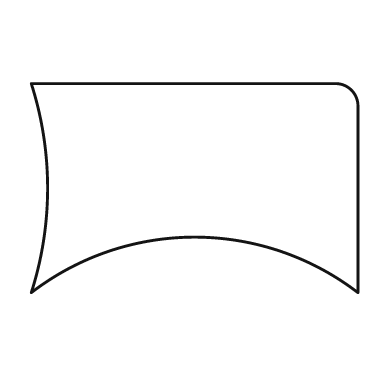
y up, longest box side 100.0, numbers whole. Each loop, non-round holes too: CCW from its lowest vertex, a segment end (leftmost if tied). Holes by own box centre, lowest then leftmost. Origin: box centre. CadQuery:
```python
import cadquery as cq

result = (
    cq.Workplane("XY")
    .moveTo(-50.0, -32.0)
    .threePointArc((0.0, -15.0), (50.0, -32.0))
    .lineTo(50.0, 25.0)
    .threePointArc((48.0, 30.0), (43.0, 32.0))
    .lineTo(-50.0, 32.0)
    .threePointArc((-45.0, 0.0), (-50.0, -32.0))
    .close()
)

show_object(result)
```